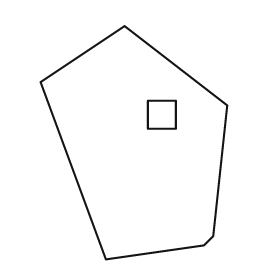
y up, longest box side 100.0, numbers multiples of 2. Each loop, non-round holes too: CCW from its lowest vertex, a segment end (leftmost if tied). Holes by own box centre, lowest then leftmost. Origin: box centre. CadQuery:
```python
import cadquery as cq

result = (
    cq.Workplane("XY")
    .moveTo(-12.0, -50.0)
    .lineTo(30.0, -44.0)
    .lineTo(34.0, -40.0)
    .lineTo(40.0, 16.0)
    .lineTo(-4.0, 50.0)
    .lineTo(-40.0, 26.0)
    .close()
    .moveTo(6.0, 6.0)
    .lineTo(18.0, 6.0)
    .lineTo(18.0, 18.0)
    .lineTo(6.0, 18.0)
    .close()
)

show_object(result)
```